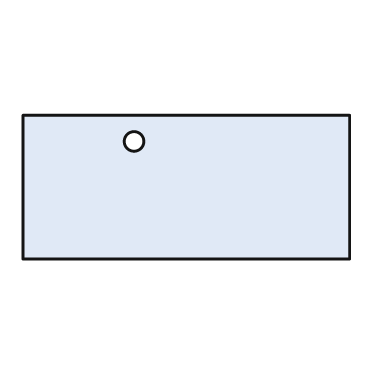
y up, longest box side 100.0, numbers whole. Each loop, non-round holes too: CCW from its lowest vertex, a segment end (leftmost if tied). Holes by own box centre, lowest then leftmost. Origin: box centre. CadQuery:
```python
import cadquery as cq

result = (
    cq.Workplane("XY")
    .moveTo(-50.0, -22.0)
    .lineTo(50.0, -22.0)
    .lineTo(50.0, 22.0)
    .lineTo(-50.0, 22.0)
    .close()
    .moveTo(-16.0, 14.0)
    .circle(3.0)
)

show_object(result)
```